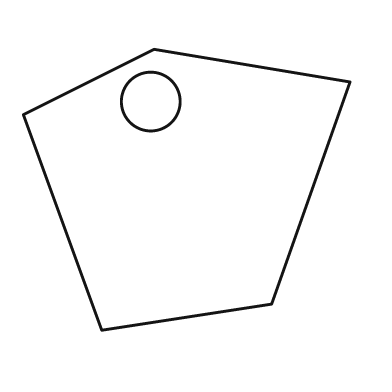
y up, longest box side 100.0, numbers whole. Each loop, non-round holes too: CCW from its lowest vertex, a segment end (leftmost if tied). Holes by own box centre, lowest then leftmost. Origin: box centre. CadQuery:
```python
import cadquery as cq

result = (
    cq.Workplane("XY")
    .moveTo(-26.0, -43.0)
    .lineTo(26.0, -35.0)
    .lineTo(50.0, 33.0)
    .lineTo(-10.0, 43.0)
    .lineTo(-50.0, 23.0)
    .close()
    .moveTo(-11.0, 27.0)
    .circle(9.0)
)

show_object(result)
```